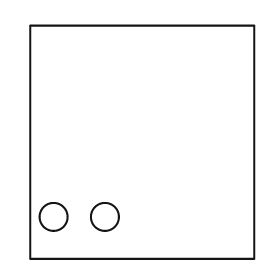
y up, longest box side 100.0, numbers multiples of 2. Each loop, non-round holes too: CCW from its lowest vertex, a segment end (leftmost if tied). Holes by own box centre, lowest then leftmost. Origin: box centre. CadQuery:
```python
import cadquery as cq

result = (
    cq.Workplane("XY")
    .moveTo(-48.0, -50.0)
    .lineTo(48.0, -50.0)
    .lineTo(48.0, 50.0)
    .lineTo(-48.0, 50.0)
    .close()
    .moveTo(-38.0, -32.0)
    .circle(6.0)
    .moveTo(-16.0, -32.0)
    .circle(6.0)
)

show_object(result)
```